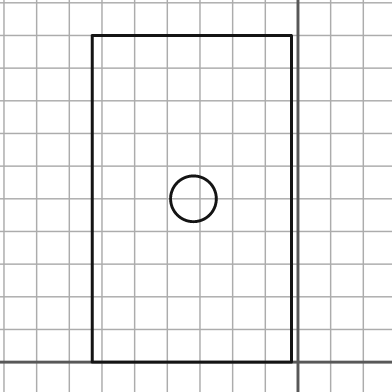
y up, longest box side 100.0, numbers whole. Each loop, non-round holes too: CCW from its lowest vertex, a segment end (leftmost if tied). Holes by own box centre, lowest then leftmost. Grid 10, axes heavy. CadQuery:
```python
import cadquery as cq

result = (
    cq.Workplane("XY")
    .moveTo(-63.0, 0.0)
    .lineTo(-2.0, 0.0)
    .lineTo(-2.0, 100.0)
    .lineTo(-63.0, 100.0)
    .close()
    .moveTo(-32.0, 50.0)
    .circle(7.0)
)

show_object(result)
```